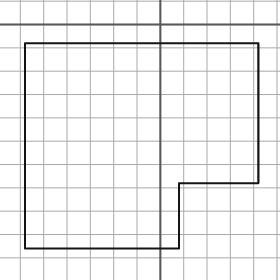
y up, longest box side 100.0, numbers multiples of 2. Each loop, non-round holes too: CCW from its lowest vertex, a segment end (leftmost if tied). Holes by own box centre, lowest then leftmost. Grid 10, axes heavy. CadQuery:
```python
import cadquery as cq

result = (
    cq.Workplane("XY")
    .moveTo(-58.0, -96.0)
    .lineTo(8.0, -96.0)
    .lineTo(8.0, -68.0)
    .lineTo(42.0, -68.0)
    .lineTo(42.0, -8.0)
    .lineTo(-58.0, -8.0)
    .close()
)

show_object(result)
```